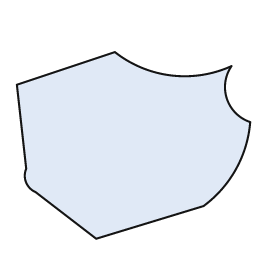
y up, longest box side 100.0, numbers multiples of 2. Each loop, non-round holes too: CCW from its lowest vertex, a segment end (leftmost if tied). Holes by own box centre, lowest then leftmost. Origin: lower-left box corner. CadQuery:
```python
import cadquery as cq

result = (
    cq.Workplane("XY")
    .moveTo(34.0, 0.0)
    .lineTo(80.0, 14.0)
    .threePointArc((94.0, 30.0), (100.0, 50.0))
    .threePointArc((90.0, 60.0), (92.0, 74.0))
    .threePointArc((66.0, 70.0), (42.0, 80.0))
    .lineTo(0.0, 66.0)
    .lineTo(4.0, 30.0)
    .threePointArc((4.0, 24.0), (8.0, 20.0))
    .close()
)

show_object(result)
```